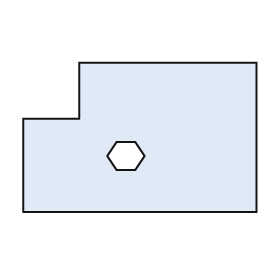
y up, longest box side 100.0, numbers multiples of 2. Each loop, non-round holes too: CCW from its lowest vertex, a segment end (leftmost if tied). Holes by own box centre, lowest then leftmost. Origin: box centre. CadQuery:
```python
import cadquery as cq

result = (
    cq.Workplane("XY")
    .moveTo(-50.0, -32.0)
    .lineTo(50.0, -32.0)
    .lineTo(50.0, 32.0)
    .lineTo(-26.0, 32.0)
    .lineTo(-26.0, 8.0)
    .lineTo(-50.0, 8.0)
    .close()
    .moveTo(-10.0, -14.0)
    .lineTo(-2.0, -14.0)
    .lineTo(2.0, -8.0)
    .lineTo(-2.0, -2.0)
    .lineTo(-10.0, -2.0)
    .lineTo(-14.0, -8.0)
    .close()
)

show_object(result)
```